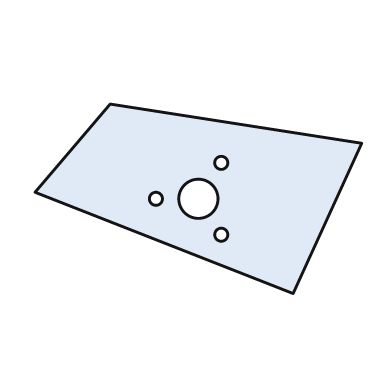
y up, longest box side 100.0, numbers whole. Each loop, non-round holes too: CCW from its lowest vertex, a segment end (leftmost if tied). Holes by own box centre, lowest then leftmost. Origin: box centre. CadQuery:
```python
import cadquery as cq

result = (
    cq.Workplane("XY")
    .moveTo(29.0, -29.0)
    .lineTo(50.0, 17.0)
    .lineTo(-27.0, 29.0)
    .lineTo(-50.0, 2.0)
    .close()
    .moveTo(7.0, -11.0)
    .circle(2.0)
    .moveTo(-13.0, 0.0)
    .circle(2.0)
    .moveTo(0.0, 0.0)
    .circle(6.0)
    .moveTo(7.0, 11.0)
    .circle(2.0)
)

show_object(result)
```